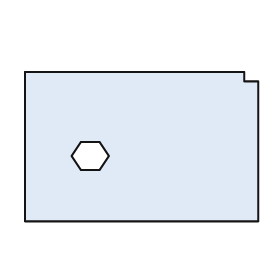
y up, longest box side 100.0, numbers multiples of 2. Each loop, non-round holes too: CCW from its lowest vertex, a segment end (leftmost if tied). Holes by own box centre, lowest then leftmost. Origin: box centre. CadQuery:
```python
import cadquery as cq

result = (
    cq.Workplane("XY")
    .moveTo(-50.0, -32.0)
    .lineTo(50.0, -32.0)
    .lineTo(50.0, 28.0)
    .lineTo(44.0, 28.0)
    .lineTo(44.0, 32.0)
    .lineTo(-50.0, 32.0)
    .close()
    .moveTo(-26.0, -10.0)
    .lineTo(-18.0, -10.0)
    .lineTo(-14.0, -4.0)
    .lineTo(-18.0, 2.0)
    .lineTo(-26.0, 2.0)
    .lineTo(-30.0, -4.0)
    .close()
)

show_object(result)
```